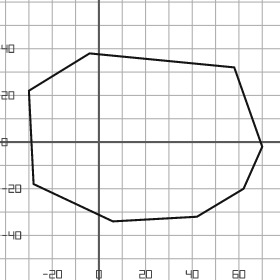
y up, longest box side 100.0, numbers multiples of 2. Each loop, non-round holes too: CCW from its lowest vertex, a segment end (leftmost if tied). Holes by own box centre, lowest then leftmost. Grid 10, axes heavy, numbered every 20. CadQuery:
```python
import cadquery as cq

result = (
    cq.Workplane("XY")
    .moveTo(6.0, -34.0)
    .lineTo(42.0, -32.0)
    .lineTo(62.0, -20.0)
    .lineTo(70.0, -2.0)
    .lineTo(58.0, 32.0)
    .lineTo(-4.0, 38.0)
    .lineTo(-30.0, 22.0)
    .lineTo(-28.0, -18.0)
    .close()
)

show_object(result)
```